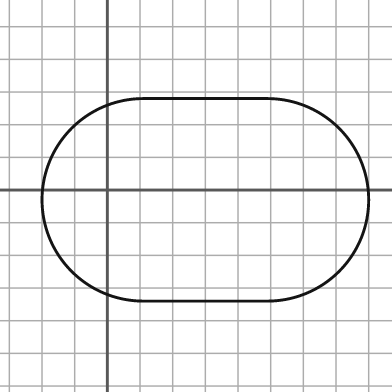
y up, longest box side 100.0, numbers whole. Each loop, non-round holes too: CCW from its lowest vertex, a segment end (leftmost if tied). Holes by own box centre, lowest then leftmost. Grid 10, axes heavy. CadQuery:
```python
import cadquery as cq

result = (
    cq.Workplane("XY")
    .moveTo(11.0, -34.0)
    .lineTo(49.0, -34.0)
    .threePointArc((80.0, -3.0), (49.0, 28.0))
    .lineTo(11.0, 28.0)
    .threePointArc((-20.0, -3.0), (11.0, -34.0))
    .close()
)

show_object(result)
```